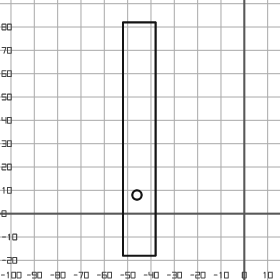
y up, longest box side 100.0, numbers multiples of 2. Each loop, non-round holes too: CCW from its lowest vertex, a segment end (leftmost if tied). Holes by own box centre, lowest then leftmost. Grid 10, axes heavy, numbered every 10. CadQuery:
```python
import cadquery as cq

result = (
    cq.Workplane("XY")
    .moveTo(-52.0, -18.0)
    .lineTo(-38.0, -18.0)
    .lineTo(-38.0, 82.0)
    .lineTo(-52.0, 82.0)
    .close()
    .moveTo(-46.0, 8.0)
    .circle(2.0)
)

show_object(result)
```